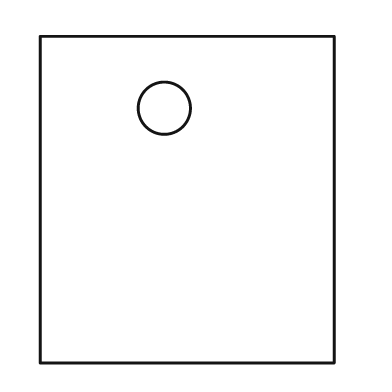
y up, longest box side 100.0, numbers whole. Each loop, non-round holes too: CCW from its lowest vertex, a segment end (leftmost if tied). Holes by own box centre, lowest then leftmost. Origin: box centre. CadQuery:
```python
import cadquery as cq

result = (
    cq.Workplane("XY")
    .moveTo(-45.0, -50.0)
    .lineTo(45.0, -50.0)
    .lineTo(45.0, 50.0)
    .lineTo(-45.0, 50.0)
    .close()
    .moveTo(-7.0, 28.0)
    .circle(8.0)
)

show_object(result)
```